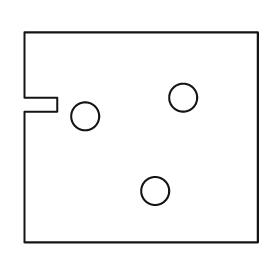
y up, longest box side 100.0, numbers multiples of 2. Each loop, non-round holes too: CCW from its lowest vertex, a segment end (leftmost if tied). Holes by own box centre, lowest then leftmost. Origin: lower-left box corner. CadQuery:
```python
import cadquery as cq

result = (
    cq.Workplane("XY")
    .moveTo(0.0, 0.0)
    .lineTo(100.0, 0.0)
    .lineTo(100.0, 90.0)
    .lineTo(0.0, 90.0)
    .lineTo(0.0, 62.0)
    .lineTo(14.0, 62.0)
    .lineTo(14.0, 56.0)
    .lineTo(0.0, 56.0)
    .close()
    .moveTo(56.0, 22.0)
    .circle(6.0)
    .moveTo(26.0, 54.0)
    .circle(6.0)
    .moveTo(68.0, 62.0)
    .circle(6.0)
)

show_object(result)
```